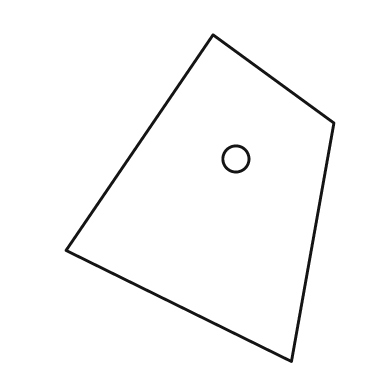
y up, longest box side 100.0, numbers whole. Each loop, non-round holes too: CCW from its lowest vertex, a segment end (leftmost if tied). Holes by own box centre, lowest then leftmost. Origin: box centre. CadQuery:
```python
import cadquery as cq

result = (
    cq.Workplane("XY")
    .moveTo(28.0, -50.0)
    .lineTo(41.0, 23.0)
    .lineTo(4.0, 50.0)
    .lineTo(-41.0, -16.0)
    .close()
    .moveTo(11.0, 12.0)
    .circle(4.0)
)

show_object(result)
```